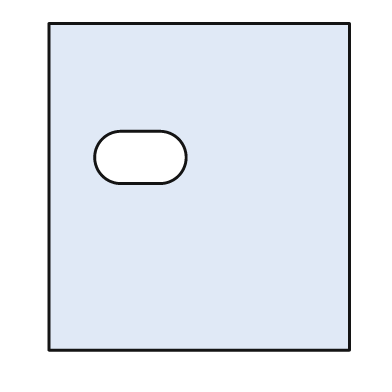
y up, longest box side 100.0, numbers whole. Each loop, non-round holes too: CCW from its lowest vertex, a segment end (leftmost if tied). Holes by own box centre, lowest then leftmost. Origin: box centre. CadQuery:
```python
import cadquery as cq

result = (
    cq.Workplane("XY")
    .moveTo(-46.0, -50.0)
    .lineTo(46.0, -50.0)
    .lineTo(46.0, 50.0)
    .lineTo(-46.0, 50.0)
    .close()
    .moveTo(-24.0, 1.0)
    .lineTo(-12.0, 1.0)
    .threePointArc((-4.0, 9.0), (-12.0, 17.0))
    .lineTo(-24.0, 17.0)
    .threePointArc((-32.0, 9.0), (-24.0, 1.0))
    .close()
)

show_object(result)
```